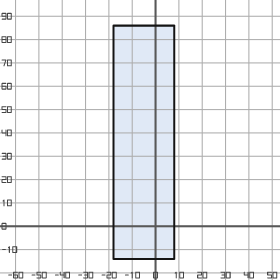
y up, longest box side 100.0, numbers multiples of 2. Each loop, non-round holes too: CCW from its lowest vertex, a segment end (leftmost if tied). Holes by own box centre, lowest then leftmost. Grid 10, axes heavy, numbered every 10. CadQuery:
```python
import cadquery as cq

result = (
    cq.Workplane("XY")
    .moveTo(-18.0, -14.0)
    .lineTo(8.0, -14.0)
    .lineTo(8.0, 86.0)
    .lineTo(-18.0, 86.0)
    .close()
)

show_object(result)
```